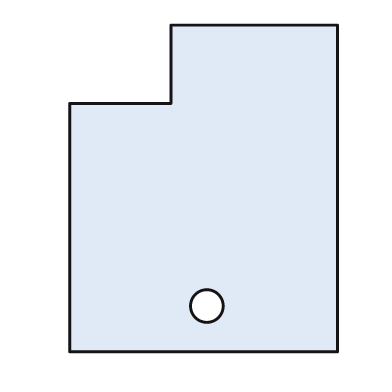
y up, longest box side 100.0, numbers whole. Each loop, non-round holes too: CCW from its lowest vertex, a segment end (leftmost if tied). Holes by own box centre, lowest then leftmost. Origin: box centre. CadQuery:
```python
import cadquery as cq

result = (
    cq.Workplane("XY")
    .moveTo(-41.0, -50.0)
    .lineTo(41.0, -50.0)
    .lineTo(41.0, 50.0)
    .lineTo(-10.0, 50.0)
    .lineTo(-10.0, 26.0)
    .lineTo(-41.0, 26.0)
    .close()
    .moveTo(1.0, -36.0)
    .circle(5.0)
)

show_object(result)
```